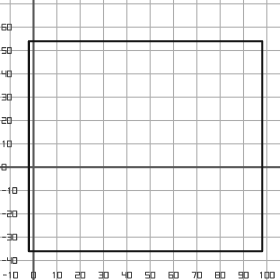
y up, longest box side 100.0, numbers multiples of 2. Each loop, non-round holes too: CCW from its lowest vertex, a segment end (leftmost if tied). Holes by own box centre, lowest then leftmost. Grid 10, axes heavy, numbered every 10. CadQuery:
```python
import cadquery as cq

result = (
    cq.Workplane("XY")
    .moveTo(-2.0, -36.0)
    .lineTo(98.0, -36.0)
    .lineTo(98.0, 54.0)
    .lineTo(-2.0, 54.0)
    .close()
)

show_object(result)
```